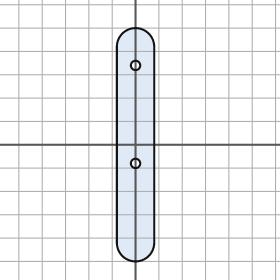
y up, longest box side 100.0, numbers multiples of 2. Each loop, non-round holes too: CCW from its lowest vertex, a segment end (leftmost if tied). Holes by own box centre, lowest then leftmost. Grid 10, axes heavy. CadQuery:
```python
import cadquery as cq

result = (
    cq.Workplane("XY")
    .moveTo(-8.0, -42.0)
    .threePointArc((0.0, -50.0), (8.0, -42.0))
    .lineTo(8.0, 42.0)
    .threePointArc((0.0, 50.0), (-8.0, 42.0))
    .close()
    .moveTo(0.0, -8.0)
    .circle(2.0)
    .moveTo(0.0, 34.0)
    .circle(2.0)
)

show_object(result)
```